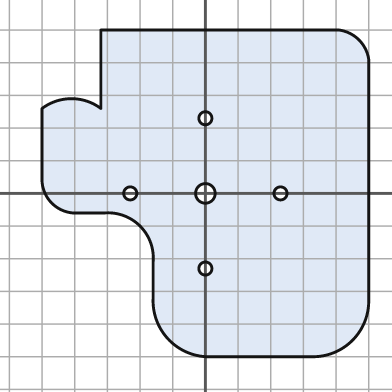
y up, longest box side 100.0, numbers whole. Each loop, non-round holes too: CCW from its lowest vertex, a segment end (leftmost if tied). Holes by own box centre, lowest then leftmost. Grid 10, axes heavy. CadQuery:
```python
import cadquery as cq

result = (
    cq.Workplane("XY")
    .moveTo(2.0, -50.0)
    .lineTo(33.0, -50.0)
    .threePointArc((45.0, -45.0), (50.0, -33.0))
    .lineTo(50.0, 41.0)
    .threePointArc((47.0, 47.0), (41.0, 50.0))
    .lineTo(-32.0, 50.0)
    .lineTo(-32.0, 26.0)
    .threePointArc((-41.0, 29.0), (-50.0, 26.0))
    .lineTo(-50.0, 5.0)
    .threePointArc((-47.0, -3.0), (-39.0, -6.0))
    .lineTo(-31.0, -6.0)
    .threePointArc((-20.0, -10.0), (-16.0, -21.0))
    .lineTo(-16.0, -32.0)
    .threePointArc((-11.0, -45.0), (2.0, -50.0))
    .close()
    .moveTo(0.0, -23.0)
    .circle(2.0)
    .moveTo(-23.0, 0.0)
    .circle(2.0)
    .moveTo(0.0, 0.0)
    .circle(3.0)
    .moveTo(23.0, 0.0)
    .circle(2.0)
    .moveTo(0.0, 23.0)
    .circle(2.0)
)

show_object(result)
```